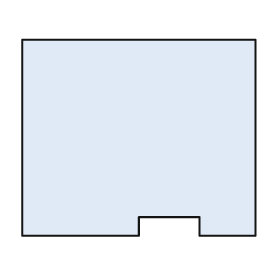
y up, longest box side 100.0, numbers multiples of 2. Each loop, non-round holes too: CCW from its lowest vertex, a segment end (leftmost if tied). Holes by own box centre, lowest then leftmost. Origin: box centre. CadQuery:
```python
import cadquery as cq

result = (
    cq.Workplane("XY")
    .moveTo(-50.0, -42.0)
    .lineTo(0.0, -42.0)
    .lineTo(0.0, -34.0)
    .lineTo(26.0, -34.0)
    .lineTo(26.0, -42.0)
    .lineTo(50.0, -42.0)
    .lineTo(50.0, 42.0)
    .lineTo(-50.0, 42.0)
    .close()
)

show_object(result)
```